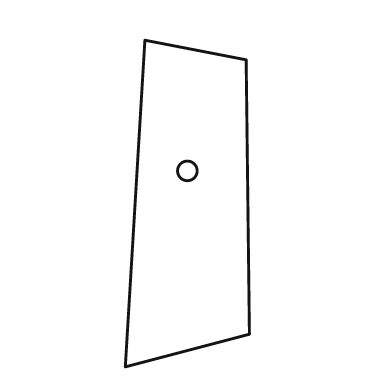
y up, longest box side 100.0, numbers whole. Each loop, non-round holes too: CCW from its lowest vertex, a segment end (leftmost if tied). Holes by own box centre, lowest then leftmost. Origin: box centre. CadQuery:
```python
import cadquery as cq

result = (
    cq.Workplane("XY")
    .moveTo(-19.0, -50.0)
    .lineTo(19.0, -40.0)
    .lineTo(18.0, 44.0)
    .lineTo(-13.0, 50.0)
    .close()
    .moveTo(0.0, 10.0)
    .circle(3.0)
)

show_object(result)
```